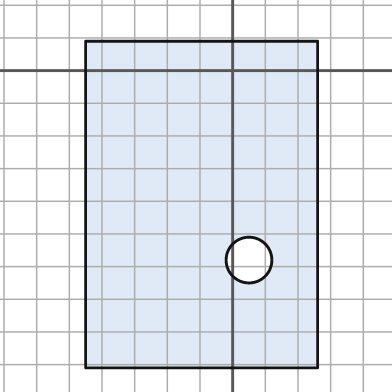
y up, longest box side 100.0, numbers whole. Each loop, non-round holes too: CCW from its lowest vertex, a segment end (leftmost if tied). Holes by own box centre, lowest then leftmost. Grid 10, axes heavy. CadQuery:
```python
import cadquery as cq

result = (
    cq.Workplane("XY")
    .moveTo(-45.0, -91.0)
    .lineTo(26.0, -91.0)
    .lineTo(26.0, 9.0)
    .lineTo(-45.0, 9.0)
    .close()
    .moveTo(5.0, -58.0)
    .circle(7.0)
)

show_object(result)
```